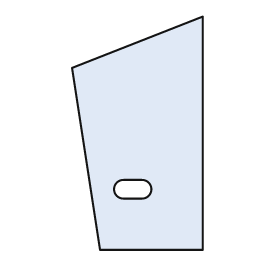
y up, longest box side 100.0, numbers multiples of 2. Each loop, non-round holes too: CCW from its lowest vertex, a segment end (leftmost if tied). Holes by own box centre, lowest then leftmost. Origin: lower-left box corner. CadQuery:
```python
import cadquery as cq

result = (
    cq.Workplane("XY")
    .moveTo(12.0, 0.0)
    .lineTo(56.0, 0.0)
    .lineTo(56.0, 100.0)
    .lineTo(0.0, 78.0)
    .close()
    .moveTo(22.0, 22.0)
    .lineTo(30.0, 22.0)
    .threePointArc((34.0, 26.0), (30.0, 30.0))
    .lineTo(22.0, 30.0)
    .threePointArc((18.0, 26.0), (22.0, 22.0))
    .close()
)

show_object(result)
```